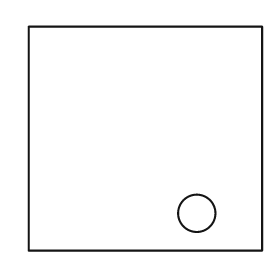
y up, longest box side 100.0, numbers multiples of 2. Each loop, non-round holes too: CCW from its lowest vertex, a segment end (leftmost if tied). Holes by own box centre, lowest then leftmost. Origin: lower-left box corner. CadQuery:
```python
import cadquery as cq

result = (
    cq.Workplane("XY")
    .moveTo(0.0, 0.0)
    .lineTo(100.0, 0.0)
    .lineTo(100.0, 96.0)
    .lineTo(0.0, 96.0)
    .close()
    .moveTo(72.0, 16.0)
    .circle(8.0)
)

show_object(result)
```